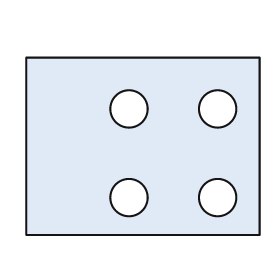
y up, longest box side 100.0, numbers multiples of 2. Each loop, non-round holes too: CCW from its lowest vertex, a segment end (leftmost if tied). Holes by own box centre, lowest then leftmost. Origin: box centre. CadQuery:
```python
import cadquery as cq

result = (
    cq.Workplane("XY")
    .moveTo(-50.0, -38.0)
    .lineTo(50.0, -38.0)
    .lineTo(50.0, 38.0)
    .lineTo(-50.0, 38.0)
    .close()
    .moveTo(-6.0, -22.0)
    .circle(8.0)
    .moveTo(32.0, -22.0)
    .circle(8.0)
    .moveTo(-6.0, 16.0)
    .circle(8.0)
    .moveTo(32.0, 16.0)
    .circle(8.0)
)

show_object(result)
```